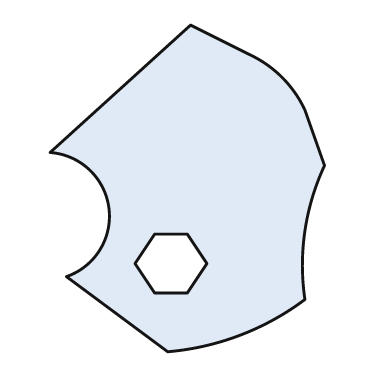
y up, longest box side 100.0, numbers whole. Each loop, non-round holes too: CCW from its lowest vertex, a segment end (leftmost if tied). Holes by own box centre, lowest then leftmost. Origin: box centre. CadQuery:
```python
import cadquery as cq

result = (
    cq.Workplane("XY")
    .moveTo(-6.0, -50.0)
    .threePointArc((16.0, -45.0), (36.0, -34.0))
    .threePointArc((36.0, -13.0), (42.0, 7.0))
    .lineTo(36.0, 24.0)
    .threePointArc((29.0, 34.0), (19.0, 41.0))
    .lineTo(1.0, 50.0)
    .lineTo(-42.0, 11.0)
    .threePointArc((-24.0, -6.0), (-37.0, -27.0))
    .close()
    .moveTo(-10.0, -32.0)
    .lineTo(0.0, -32.0)
    .lineTo(6.0, -23.0)
    .lineTo(0.0, -14.0)
    .lineTo(-10.0, -14.0)
    .lineTo(-16.0, -23.0)
    .close()
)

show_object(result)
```